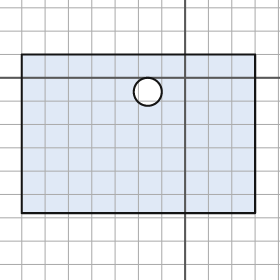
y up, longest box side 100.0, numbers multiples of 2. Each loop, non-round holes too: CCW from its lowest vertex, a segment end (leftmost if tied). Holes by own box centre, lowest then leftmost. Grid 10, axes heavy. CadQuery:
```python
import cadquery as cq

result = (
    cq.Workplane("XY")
    .moveTo(-70.0, -58.0)
    .lineTo(30.0, -58.0)
    .lineTo(30.0, 10.0)
    .lineTo(-70.0, 10.0)
    .close()
    .moveTo(-16.0, -6.0)
    .circle(6.0)
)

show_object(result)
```